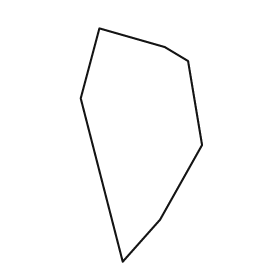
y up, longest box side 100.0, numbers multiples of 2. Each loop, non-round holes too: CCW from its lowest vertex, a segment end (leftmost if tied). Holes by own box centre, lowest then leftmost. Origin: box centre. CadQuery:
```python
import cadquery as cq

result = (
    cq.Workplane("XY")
    .moveTo(-8.0, -50.0)
    .lineTo(8.0, -32.0)
    .lineTo(26.0, 0.0)
    .lineTo(20.0, 36.0)
    .lineTo(10.0, 42.0)
    .lineTo(-18.0, 50.0)
    .lineTo(-26.0, 20.0)
    .close()
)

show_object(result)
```